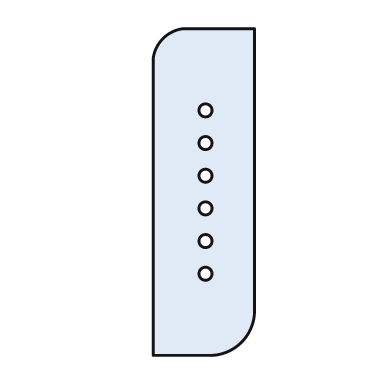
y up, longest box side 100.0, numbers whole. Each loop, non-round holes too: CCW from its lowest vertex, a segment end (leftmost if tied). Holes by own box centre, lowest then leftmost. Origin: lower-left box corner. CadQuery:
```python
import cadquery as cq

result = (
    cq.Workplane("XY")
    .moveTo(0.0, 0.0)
    .lineTo(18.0, 0.0)
    .threePointArc((27.0, 4.0), (31.0, 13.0))
    .lineTo(31.0, 100.0)
    .lineTo(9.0, 100.0)
    .threePointArc((3.0, 97.0), (0.0, 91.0))
    .close()
    .moveTo(16.0, 25.0)
    .circle(2.0)
    .moveTo(16.0, 35.0)
    .circle(2.0)
    .moveTo(16.0, 45.0)
    .circle(2.0)
    .moveTo(16.0, 55.0)
    .circle(2.0)
    .moveTo(16.0, 65.0)
    .circle(2.0)
    .moveTo(16.0, 75.0)
    .circle(2.0)
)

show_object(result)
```